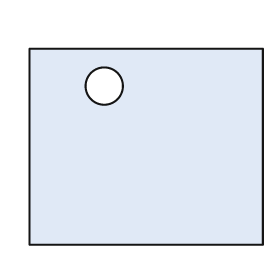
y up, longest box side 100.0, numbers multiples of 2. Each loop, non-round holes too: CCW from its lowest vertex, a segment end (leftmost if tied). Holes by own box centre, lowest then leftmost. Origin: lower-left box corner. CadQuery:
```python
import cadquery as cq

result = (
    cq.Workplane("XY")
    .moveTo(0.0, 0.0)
    .lineTo(100.0, 0.0)
    .lineTo(100.0, 84.0)
    .lineTo(0.0, 84.0)
    .close()
    .moveTo(32.0, 68.0)
    .circle(8.0)
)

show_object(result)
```